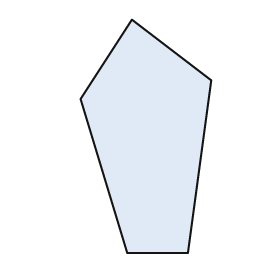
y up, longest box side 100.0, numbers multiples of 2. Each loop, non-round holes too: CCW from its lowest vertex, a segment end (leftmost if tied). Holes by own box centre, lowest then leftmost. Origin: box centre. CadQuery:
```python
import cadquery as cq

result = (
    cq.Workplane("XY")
    .moveTo(-8.0, -50.0)
    .lineTo(18.0, -50.0)
    .lineTo(28.0, 24.0)
    .lineTo(-6.0, 50.0)
    .lineTo(-28.0, 16.0)
    .close()
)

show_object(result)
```